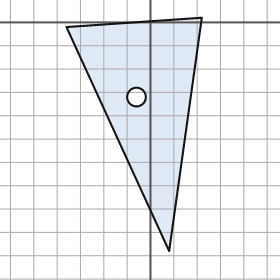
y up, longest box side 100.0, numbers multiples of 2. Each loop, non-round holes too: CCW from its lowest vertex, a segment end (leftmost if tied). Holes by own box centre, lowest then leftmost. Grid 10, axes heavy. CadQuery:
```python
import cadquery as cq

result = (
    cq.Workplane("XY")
    .moveTo(8.0, -98.0)
    .lineTo(22.0, 2.0)
    .lineTo(-36.0, -2.0)
    .close()
    .moveTo(-6.0, -32.0)
    .circle(4.0)
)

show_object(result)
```